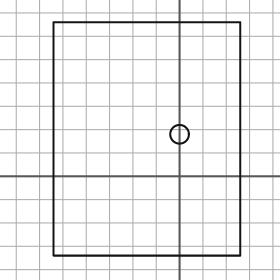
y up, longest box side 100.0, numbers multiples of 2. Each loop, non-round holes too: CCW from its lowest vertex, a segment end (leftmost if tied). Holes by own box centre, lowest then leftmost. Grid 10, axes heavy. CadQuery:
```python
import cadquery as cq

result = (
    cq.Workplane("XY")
    .moveTo(-54.0, -34.0)
    .lineTo(26.0, -34.0)
    .lineTo(26.0, 66.0)
    .lineTo(-54.0, 66.0)
    .close()
    .moveTo(0.0, 18.0)
    .circle(4.0)
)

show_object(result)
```